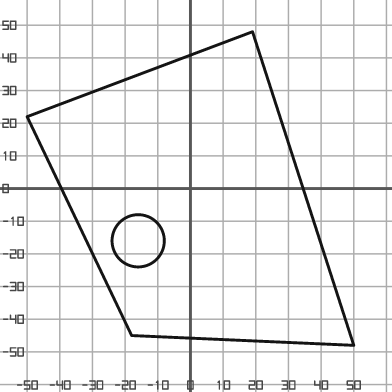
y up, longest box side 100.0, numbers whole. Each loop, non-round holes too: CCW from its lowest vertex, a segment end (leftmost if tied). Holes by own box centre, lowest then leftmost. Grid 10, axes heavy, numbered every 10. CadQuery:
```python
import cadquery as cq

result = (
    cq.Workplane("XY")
    .moveTo(50.0, -48.0)
    .lineTo(19.0, 48.0)
    .lineTo(-50.0, 22.0)
    .lineTo(-18.0, -45.0)
    .close()
    .moveTo(-16.0, -16.0)
    .circle(8.0)
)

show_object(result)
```